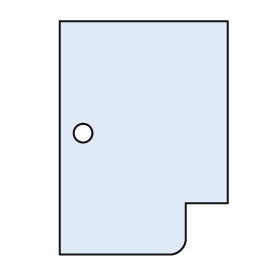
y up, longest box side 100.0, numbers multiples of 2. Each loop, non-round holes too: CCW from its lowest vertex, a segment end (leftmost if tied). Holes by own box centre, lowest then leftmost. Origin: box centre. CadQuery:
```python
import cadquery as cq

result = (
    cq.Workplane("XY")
    .moveTo(-36.0, -50.0)
    .lineTo(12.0, -50.0)
    .threePointArc((16.0, -48.0), (18.0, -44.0))
    .lineTo(18.0, -28.0)
    .lineTo(36.0, -28.0)
    .lineTo(36.0, 50.0)
    .lineTo(-36.0, 50.0)
    .close()
    .moveTo(-26.0, 2.0)
    .circle(4.0)
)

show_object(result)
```